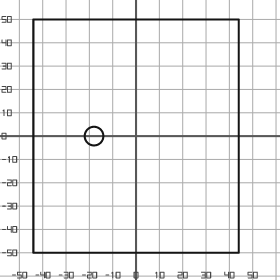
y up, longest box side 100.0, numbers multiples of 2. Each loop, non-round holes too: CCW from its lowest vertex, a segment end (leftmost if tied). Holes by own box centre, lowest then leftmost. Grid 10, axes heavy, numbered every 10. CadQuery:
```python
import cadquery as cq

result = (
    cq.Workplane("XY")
    .moveTo(-44.0, -50.0)
    .lineTo(44.0, -50.0)
    .lineTo(44.0, 50.0)
    .lineTo(-44.0, 50.0)
    .close()
    .moveTo(-18.0, 0.0)
    .circle(4.0)
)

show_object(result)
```